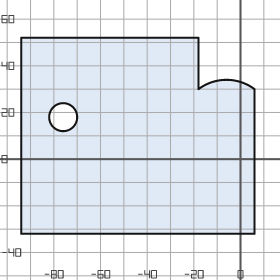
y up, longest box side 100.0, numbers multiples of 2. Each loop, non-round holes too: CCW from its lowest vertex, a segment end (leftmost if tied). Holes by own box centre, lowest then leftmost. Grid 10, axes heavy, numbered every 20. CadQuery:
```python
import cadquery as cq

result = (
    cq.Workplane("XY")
    .moveTo(-94.0, -32.0)
    .lineTo(6.0, -32.0)
    .lineTo(6.0, 30.0)
    .threePointArc((-6.0, 34.0), (-18.0, 30.0))
    .lineTo(-18.0, 52.0)
    .lineTo(-94.0, 52.0)
    .close()
    .moveTo(-76.0, 18.0)
    .circle(6.0)
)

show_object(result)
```